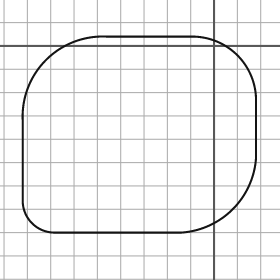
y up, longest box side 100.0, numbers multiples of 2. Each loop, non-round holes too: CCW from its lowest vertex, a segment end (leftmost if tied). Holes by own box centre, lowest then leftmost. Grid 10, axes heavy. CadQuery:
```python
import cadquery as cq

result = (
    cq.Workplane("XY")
    .moveTo(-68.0, -80.0)
    .lineTo(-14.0, -80.0)
    .threePointArc((8.0, -70.0), (18.0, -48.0))
    .lineTo(18.0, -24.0)
    .threePointArc((10.0, -4.0), (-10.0, 4.0))
    .lineTo(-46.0, 4.0)
    .threePointArc((-72.0, -6.0), (-82.0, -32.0))
    .lineTo(-82.0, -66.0)
    .threePointArc((-78.0, -76.0), (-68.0, -80.0))
    .close()
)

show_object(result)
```